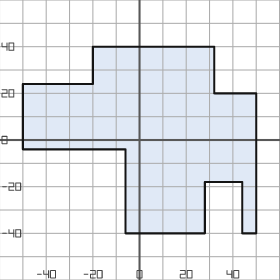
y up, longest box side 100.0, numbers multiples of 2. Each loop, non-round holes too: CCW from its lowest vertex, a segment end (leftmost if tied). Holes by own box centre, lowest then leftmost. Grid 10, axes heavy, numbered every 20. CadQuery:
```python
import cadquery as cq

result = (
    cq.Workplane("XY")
    .moveTo(-6.0, -40.0)
    .lineTo(28.0, -40.0)
    .lineTo(28.0, -18.0)
    .lineTo(44.0, -18.0)
    .lineTo(44.0, -40.0)
    .lineTo(50.0, -40.0)
    .lineTo(50.0, 20.0)
    .lineTo(32.0, 20.0)
    .lineTo(32.0, 40.0)
    .lineTo(-20.0, 40.0)
    .lineTo(-20.0, 24.0)
    .lineTo(-50.0, 24.0)
    .lineTo(-50.0, -4.0)
    .lineTo(-6.0, -4.0)
    .close()
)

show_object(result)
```